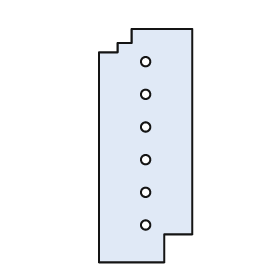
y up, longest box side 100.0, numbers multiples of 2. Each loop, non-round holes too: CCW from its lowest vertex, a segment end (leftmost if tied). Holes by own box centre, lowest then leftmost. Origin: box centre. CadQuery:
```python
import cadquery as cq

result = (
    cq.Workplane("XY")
    .moveTo(-20.0, -50.0)
    .lineTo(8.0, -50.0)
    .lineTo(8.0, -38.0)
    .lineTo(20.0, -38.0)
    .lineTo(20.0, 50.0)
    .lineTo(-6.0, 50.0)
    .lineTo(-6.0, 44.0)
    .lineTo(-12.0, 44.0)
    .lineTo(-12.0, 40.0)
    .lineTo(-20.0, 40.0)
    .close()
    .moveTo(0.0, -34.0)
    .circle(2.0)
    .moveTo(0.0, -20.0)
    .circle(2.0)
    .moveTo(0.0, -6.0)
    .circle(2.0)
    .moveTo(0.0, 8.0)
    .circle(2.0)
    .moveTo(0.0, 22.0)
    .circle(2.0)
    .moveTo(0.0, 36.0)
    .circle(2.0)
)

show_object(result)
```